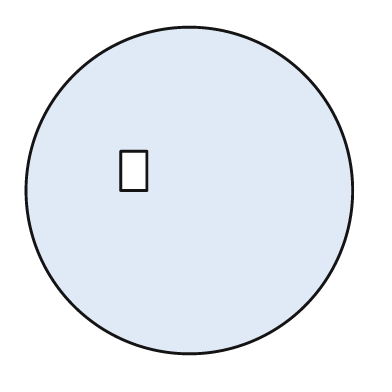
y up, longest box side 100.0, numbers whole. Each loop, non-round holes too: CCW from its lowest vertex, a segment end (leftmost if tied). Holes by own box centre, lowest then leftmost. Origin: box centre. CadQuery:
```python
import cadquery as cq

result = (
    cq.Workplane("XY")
    .moveTo(0.0, 0.0)
    .circle(50.0)
    .moveTo(-21.0, 0.0)
    .lineTo(-13.0, 0.0)
    .lineTo(-13.0, 12.0)
    .lineTo(-21.0, 12.0)
    .close()
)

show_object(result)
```